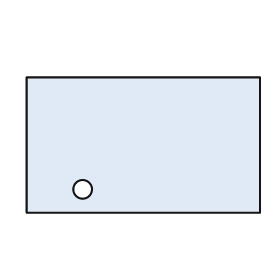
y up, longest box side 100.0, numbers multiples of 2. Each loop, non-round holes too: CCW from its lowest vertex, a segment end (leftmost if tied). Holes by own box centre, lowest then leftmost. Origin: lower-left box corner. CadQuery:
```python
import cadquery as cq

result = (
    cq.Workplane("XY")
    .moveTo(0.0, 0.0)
    .lineTo(100.0, 0.0)
    .lineTo(100.0, 58.0)
    .lineTo(0.0, 58.0)
    .close()
    .moveTo(24.0, 10.0)
    .circle(4.0)
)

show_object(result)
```